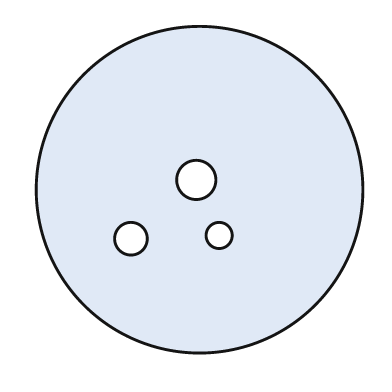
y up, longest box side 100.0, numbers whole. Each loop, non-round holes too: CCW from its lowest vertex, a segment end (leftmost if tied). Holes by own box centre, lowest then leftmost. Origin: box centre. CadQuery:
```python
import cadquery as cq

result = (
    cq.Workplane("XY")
    .moveTo(0.0, 0.0)
    .circle(50.0)
    .moveTo(-21.0, -15.0)
    .circle(5.0)
    .moveTo(6.0, -14.0)
    .circle(4.0)
    .moveTo(-1.0, 3.0)
    .circle(6.0)
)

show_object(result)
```